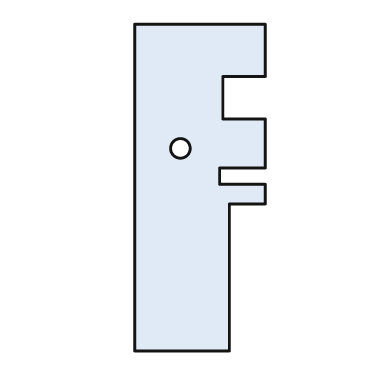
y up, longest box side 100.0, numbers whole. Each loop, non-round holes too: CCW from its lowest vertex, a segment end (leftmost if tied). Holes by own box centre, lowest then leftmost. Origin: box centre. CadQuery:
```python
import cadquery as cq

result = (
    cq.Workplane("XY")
    .moveTo(-20.0, -50.0)
    .lineTo(9.0, -50.0)
    .lineTo(9.0, -5.0)
    .lineTo(20.0, -5.0)
    .lineTo(20.0, 1.0)
    .lineTo(6.0, 1.0)
    .lineTo(6.0, 6.0)
    .lineTo(20.0, 6.0)
    .lineTo(20.0, 21.0)
    .lineTo(7.0, 21.0)
    .lineTo(7.0, 34.0)
    .lineTo(20.0, 34.0)
    .lineTo(20.0, 50.0)
    .lineTo(-20.0, 50.0)
    .close()
    .moveTo(-6.0, 12.0)
    .circle(3.0)
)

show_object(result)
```